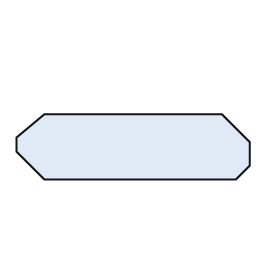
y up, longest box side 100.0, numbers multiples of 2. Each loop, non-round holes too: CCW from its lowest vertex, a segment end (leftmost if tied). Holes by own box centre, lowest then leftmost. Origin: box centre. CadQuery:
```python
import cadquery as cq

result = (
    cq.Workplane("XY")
    .moveTo(-38.0, -14.0)
    .lineTo(44.0, -14.0)
    .lineTo(50.0, -8.0)
    .lineTo(50.0, 2.0)
    .lineTo(38.0, 14.0)
    .lineTo(-38.0, 14.0)
    .lineTo(-50.0, 4.0)
    .lineTo(-50.0, -2.0)
    .close()
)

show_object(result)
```